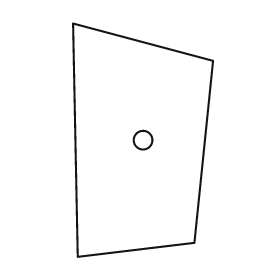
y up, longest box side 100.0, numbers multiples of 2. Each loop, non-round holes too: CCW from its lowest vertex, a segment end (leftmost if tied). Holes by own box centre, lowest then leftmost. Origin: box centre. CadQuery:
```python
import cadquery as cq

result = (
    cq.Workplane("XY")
    .moveTo(-28.0, -50.0)
    .lineTo(22.0, -44.0)
    .lineTo(30.0, 34.0)
    .lineTo(-30.0, 50.0)
    .close()
    .moveTo(0.0, 0.0)
    .circle(4.0)
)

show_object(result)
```